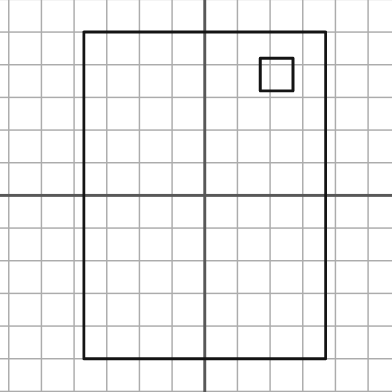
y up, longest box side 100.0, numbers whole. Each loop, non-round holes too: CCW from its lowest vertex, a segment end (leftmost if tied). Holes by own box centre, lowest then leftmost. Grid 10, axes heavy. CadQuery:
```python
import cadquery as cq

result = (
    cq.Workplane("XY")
    .moveTo(-37.0, -50.0)
    .lineTo(37.0, -50.0)
    .lineTo(37.0, 50.0)
    .lineTo(-37.0, 50.0)
    .close()
    .moveTo(17.0, 32.0)
    .lineTo(27.0, 32.0)
    .lineTo(27.0, 42.0)
    .lineTo(17.0, 42.0)
    .close()
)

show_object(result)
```